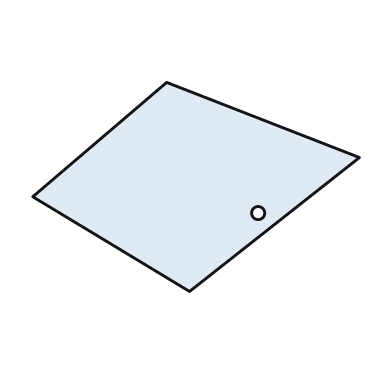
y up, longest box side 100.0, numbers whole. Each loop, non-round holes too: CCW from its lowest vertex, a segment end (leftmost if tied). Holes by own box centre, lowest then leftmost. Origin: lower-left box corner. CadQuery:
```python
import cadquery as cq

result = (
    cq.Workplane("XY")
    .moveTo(48.0, 0.0)
    .lineTo(100.0, 41.0)
    .lineTo(41.0, 64.0)
    .lineTo(0.0, 29.0)
    .close()
    .moveTo(69.0, 24.0)
    .circle(2.0)
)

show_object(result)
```